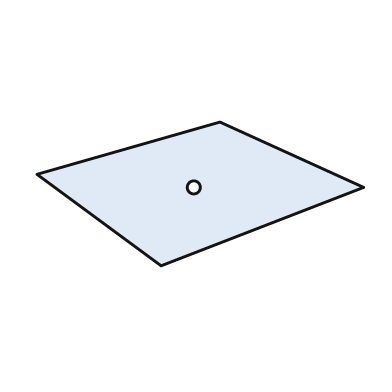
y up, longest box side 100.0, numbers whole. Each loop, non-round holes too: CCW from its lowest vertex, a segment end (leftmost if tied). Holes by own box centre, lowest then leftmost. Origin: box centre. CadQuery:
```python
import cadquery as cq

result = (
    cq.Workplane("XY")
    .moveTo(-12.0, -22.0)
    .lineTo(50.0, 2.0)
    .lineTo(6.0, 22.0)
    .lineTo(-50.0, 6.0)
    .close()
    .moveTo(-2.0, 2.0)
    .circle(2.0)
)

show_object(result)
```